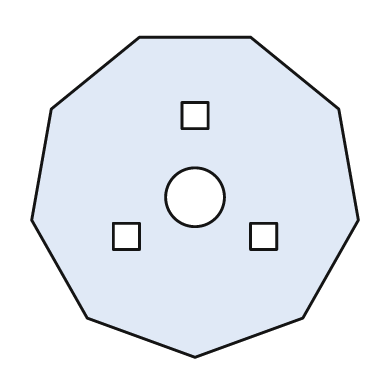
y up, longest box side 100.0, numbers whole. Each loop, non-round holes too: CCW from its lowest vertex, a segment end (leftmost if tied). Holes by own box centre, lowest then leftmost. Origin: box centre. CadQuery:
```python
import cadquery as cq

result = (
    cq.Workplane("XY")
    .moveTo(0.0, -49.0)
    .lineTo(33.0, -37.0)
    .lineTo(50.0, -7.0)
    .lineTo(44.0, 27.0)
    .lineTo(17.0, 49.0)
    .lineTo(-17.0, 49.0)
    .lineTo(-44.0, 27.0)
    .lineTo(-50.0, -7.0)
    .lineTo(-33.0, -37.0)
    .close()
    .moveTo(-25.0, -16.0)
    .lineTo(-17.0, -16.0)
    .lineTo(-17.0, -8.0)
    .lineTo(-25.0, -8.0)
    .close()
    .moveTo(17.0, -16.0)
    .lineTo(25.0, -16.0)
    .lineTo(25.0, -8.0)
    .lineTo(17.0, -8.0)
    .close()
    .moveTo(0.0, 0.0)
    .circle(9.0)
    .moveTo(-4.0, 21.0)
    .lineTo(4.0, 21.0)
    .lineTo(4.0, 29.0)
    .lineTo(-4.0, 29.0)
    .close()
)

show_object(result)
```